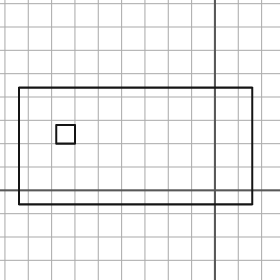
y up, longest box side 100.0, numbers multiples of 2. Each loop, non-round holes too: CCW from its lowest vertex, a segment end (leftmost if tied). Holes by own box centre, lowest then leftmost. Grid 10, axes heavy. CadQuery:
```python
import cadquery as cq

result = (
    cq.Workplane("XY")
    .moveTo(-84.0, -6.0)
    .lineTo(16.0, -6.0)
    .lineTo(16.0, 44.0)
    .lineTo(-84.0, 44.0)
    .close()
    .moveTo(-68.0, 20.0)
    .lineTo(-60.0, 20.0)
    .lineTo(-60.0, 28.0)
    .lineTo(-68.0, 28.0)
    .close()
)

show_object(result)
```